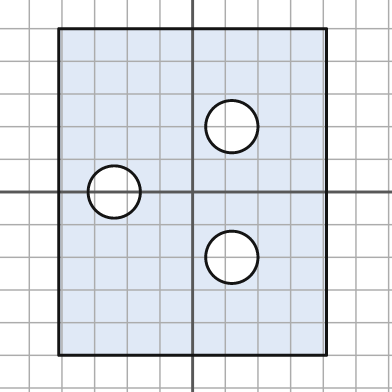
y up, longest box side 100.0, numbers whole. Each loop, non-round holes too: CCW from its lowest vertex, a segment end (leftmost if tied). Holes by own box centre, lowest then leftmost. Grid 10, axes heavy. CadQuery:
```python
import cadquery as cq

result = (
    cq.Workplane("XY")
    .moveTo(-41.0, -50.0)
    .lineTo(41.0, -50.0)
    .lineTo(41.0, 50.0)
    .lineTo(-41.0, 50.0)
    .close()
    .moveTo(12.0, -20.0)
    .circle(8.0)
    .moveTo(-24.0, 0.0)
    .circle(8.0)
    .moveTo(12.0, 20.0)
    .circle(8.0)
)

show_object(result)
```